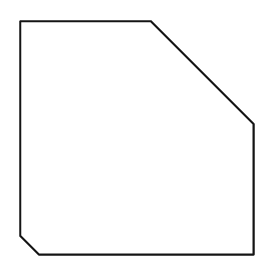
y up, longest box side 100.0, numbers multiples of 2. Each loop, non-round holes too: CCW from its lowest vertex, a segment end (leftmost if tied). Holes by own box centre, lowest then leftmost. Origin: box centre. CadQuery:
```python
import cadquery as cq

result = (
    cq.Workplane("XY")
    .moveTo(-42.0, -50.0)
    .lineTo(50.0, -50.0)
    .lineTo(50.0, 6.0)
    .lineTo(6.0, 50.0)
    .lineTo(-50.0, 50.0)
    .lineTo(-50.0, -42.0)
    .close()
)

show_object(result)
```